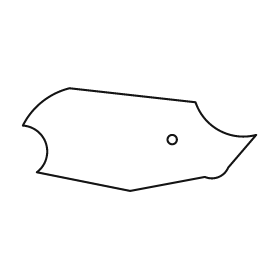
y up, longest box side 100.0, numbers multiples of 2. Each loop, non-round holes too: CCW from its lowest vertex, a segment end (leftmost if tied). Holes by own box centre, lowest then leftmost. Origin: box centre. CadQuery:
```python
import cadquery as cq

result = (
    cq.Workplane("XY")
    .moveTo(-4.0, -22.0)
    .lineTo(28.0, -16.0)
    .threePointArc((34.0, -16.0), (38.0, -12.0))
    .lineTo(50.0, 2.0)
    .threePointArc((34.0, 4.0), (24.0, 16.0))
    .lineTo(-30.0, 22.0)
    .threePointArc((-42.0, 16.0), (-50.0, 6.0))
    .threePointArc((-40.0, -2.0), (-44.0, -14.0))
    .close()
    .moveTo(14.0, 0.0)
    .circle(2.0)
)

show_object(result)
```